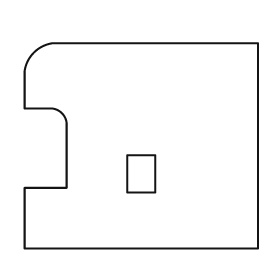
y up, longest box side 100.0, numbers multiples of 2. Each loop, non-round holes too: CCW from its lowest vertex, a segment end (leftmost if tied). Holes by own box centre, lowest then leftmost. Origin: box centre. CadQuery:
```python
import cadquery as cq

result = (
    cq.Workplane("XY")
    .moveTo(-50.0, -44.0)
    .lineTo(50.0, -44.0)
    .lineTo(50.0, 44.0)
    .lineTo(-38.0, 44.0)
    .threePointArc((-46.0, 40.0), (-50.0, 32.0))
    .lineTo(-50.0, 16.0)
    .lineTo(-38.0, 16.0)
    .threePointArc((-34.0, 14.0), (-32.0, 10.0))
    .lineTo(-32.0, -18.0)
    .lineTo(-50.0, -18.0)
    .close()
    .moveTo(-6.0, -20.0)
    .lineTo(6.0, -20.0)
    .lineTo(6.0, -4.0)
    .lineTo(-6.0, -4.0)
    .close()
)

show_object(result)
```